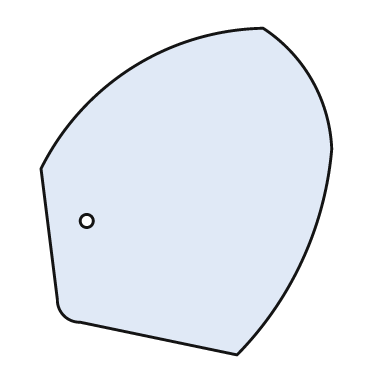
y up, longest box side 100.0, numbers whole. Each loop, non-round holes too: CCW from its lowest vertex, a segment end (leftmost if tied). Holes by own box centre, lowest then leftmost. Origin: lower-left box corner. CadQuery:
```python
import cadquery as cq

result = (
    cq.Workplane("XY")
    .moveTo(60.0, 0.0)
    .threePointArc((80.0, 29.0), (89.0, 63.0))
    .threePointArc((83.0, 84.0), (68.0, 100.0))
    .threePointArc((28.0, 88.0), (0.0, 57.0))
    .lineTo(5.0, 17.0)
    .threePointArc((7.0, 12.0), (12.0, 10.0))
    .close()
    .moveTo(14.0, 41.0)
    .circle(2.0)
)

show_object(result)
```